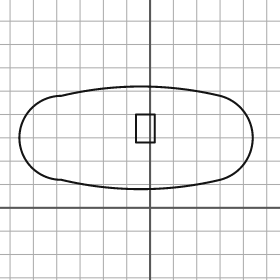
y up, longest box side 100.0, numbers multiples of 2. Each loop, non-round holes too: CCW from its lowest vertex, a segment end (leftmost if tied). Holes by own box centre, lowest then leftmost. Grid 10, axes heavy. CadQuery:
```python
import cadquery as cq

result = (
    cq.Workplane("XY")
    .moveTo(-38.0, 12.0)
    .threePointArc((-4.0, 8.0), (30.0, 12.0))
    .threePointArc((44.0, 30.0), (30.0, 48.0))
    .threePointArc((-4.0, 52.0), (-38.0, 48.0))
    .threePointArc((-56.0, 30.0), (-38.0, 12.0))
    .close()
    .moveTo(-6.0, 28.0)
    .lineTo(2.0, 28.0)
    .lineTo(2.0, 40.0)
    .lineTo(-6.0, 40.0)
    .close()
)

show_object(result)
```